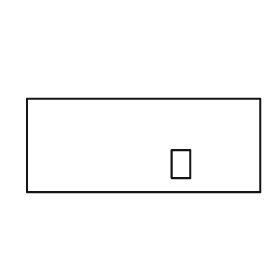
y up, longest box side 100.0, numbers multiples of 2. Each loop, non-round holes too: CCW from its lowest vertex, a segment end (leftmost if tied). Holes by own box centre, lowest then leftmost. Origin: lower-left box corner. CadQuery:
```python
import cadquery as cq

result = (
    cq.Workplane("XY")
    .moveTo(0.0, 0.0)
    .lineTo(100.0, 0.0)
    .lineTo(100.0, 40.0)
    .lineTo(0.0, 40.0)
    .close()
    .moveTo(62.0, 6.0)
    .lineTo(70.0, 6.0)
    .lineTo(70.0, 18.0)
    .lineTo(62.0, 18.0)
    .close()
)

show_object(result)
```